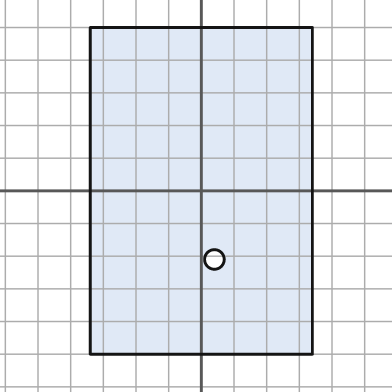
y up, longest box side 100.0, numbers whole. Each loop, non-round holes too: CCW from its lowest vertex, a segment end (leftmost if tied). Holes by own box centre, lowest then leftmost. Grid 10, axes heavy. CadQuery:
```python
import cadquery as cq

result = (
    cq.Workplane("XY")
    .moveTo(-34.0, -50.0)
    .lineTo(34.0, -50.0)
    .lineTo(34.0, 50.0)
    .lineTo(-34.0, 50.0)
    .close()
    .moveTo(4.0, -21.0)
    .circle(3.0)
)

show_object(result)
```